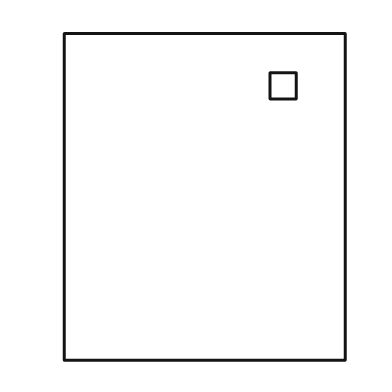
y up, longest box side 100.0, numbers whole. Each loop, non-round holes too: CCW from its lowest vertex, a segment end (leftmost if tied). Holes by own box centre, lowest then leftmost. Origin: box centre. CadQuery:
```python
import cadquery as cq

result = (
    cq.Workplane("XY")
    .moveTo(-43.0, -50.0)
    .lineTo(43.0, -50.0)
    .lineTo(43.0, 50.0)
    .lineTo(-43.0, 50.0)
    .close()
    .moveTo(20.0, 30.0)
    .lineTo(28.0, 30.0)
    .lineTo(28.0, 38.0)
    .lineTo(20.0, 38.0)
    .close()
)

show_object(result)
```